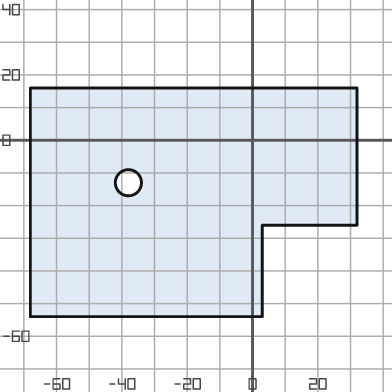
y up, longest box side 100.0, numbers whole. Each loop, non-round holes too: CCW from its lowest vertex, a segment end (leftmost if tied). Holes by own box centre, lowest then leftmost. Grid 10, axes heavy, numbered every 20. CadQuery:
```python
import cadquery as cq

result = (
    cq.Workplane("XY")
    .moveTo(-68.0, -54.0)
    .lineTo(3.0, -54.0)
    .lineTo(3.0, -26.0)
    .lineTo(32.0, -26.0)
    .lineTo(32.0, 16.0)
    .lineTo(-68.0, 16.0)
    .close()
    .moveTo(-38.0, -13.0)
    .circle(4.0)
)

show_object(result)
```